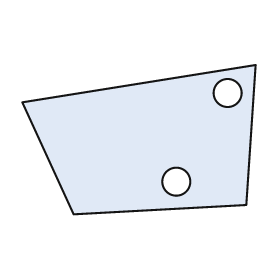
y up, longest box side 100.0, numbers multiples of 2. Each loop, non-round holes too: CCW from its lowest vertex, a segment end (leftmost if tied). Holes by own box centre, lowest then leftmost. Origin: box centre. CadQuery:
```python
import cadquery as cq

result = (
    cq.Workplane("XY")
    .moveTo(-28.0, -32.0)
    .lineTo(46.0, -28.0)
    .lineTo(50.0, 32.0)
    .lineTo(-50.0, 16.0)
    .close()
    .moveTo(16.0, -18.0)
    .circle(6.0)
    .moveTo(38.0, 20.0)
    .circle(6.0)
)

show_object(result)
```